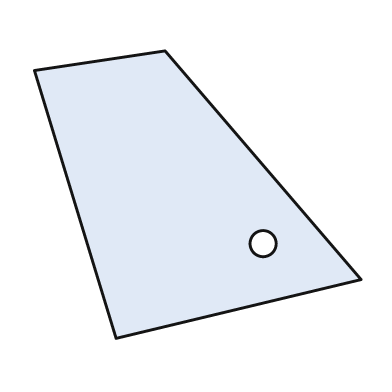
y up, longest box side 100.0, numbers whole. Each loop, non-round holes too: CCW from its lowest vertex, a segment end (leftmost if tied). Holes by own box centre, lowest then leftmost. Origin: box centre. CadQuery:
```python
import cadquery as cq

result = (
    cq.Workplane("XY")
    .moveTo(-25.0, -44.0)
    .lineTo(50.0, -26.0)
    .lineTo(-10.0, 44.0)
    .lineTo(-50.0, 38.0)
    .close()
    .moveTo(20.0, -15.0)
    .circle(4.0)
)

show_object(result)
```